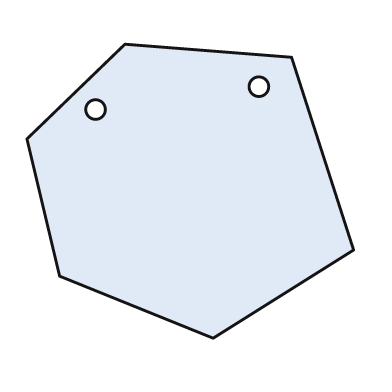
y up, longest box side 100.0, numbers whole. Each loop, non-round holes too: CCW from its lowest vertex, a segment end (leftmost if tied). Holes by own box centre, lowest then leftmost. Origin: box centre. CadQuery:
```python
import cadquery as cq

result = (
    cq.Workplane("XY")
    .moveTo(7.0, -45.0)
    .lineTo(50.0, -18.0)
    .lineTo(31.0, 41.0)
    .lineTo(-20.0, 45.0)
    .lineTo(-50.0, 16.0)
    .lineTo(-40.0, -26.0)
    .close()
    .moveTo(-29.0, 25.0)
    .circle(3.0)
    .moveTo(21.0, 32.0)
    .circle(3.0)
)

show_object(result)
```